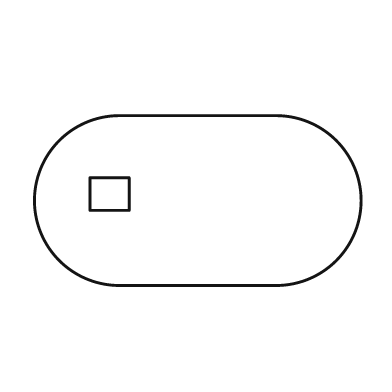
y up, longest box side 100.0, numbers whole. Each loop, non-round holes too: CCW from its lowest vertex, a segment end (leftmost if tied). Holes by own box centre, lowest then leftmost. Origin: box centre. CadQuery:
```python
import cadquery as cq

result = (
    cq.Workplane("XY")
    .moveTo(-24.0, -26.0)
    .lineTo(24.0, -26.0)
    .threePointArc((50.0, 0.0), (24.0, 26.0))
    .lineTo(-24.0, 26.0)
    .threePointArc((-50.0, 0.0), (-24.0, -26.0))
    .close()
    .moveTo(-33.0, -3.0)
    .lineTo(-21.0, -3.0)
    .lineTo(-21.0, 7.0)
    .lineTo(-33.0, 7.0)
    .close()
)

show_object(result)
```